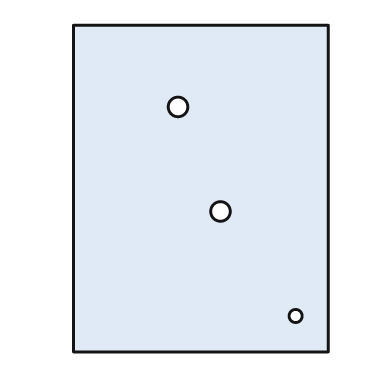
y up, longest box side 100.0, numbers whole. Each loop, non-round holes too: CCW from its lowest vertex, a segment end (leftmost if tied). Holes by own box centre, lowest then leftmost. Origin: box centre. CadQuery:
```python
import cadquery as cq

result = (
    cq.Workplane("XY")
    .moveTo(-39.0, -50.0)
    .lineTo(39.0, -50.0)
    .lineTo(39.0, 50.0)
    .lineTo(-39.0, 50.0)
    .close()
    .moveTo(29.0, -39.0)
    .circle(2.0)
    .moveTo(6.0, -7.0)
    .circle(3.0)
    .moveTo(-7.0, 25.0)
    .circle(3.0)
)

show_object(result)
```